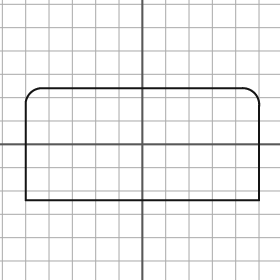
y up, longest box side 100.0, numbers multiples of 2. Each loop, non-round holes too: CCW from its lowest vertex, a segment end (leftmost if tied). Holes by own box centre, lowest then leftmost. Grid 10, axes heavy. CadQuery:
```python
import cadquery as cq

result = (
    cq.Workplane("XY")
    .moveTo(-50.0, -24.0)
    .lineTo(50.0, -24.0)
    .lineTo(50.0, 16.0)
    .threePointArc((48.0, 22.0), (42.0, 24.0))
    .lineTo(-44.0, 24.0)
    .threePointArc((-48.0, 22.0), (-50.0, 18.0))
    .close()
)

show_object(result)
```